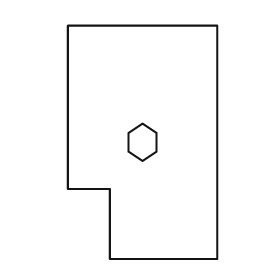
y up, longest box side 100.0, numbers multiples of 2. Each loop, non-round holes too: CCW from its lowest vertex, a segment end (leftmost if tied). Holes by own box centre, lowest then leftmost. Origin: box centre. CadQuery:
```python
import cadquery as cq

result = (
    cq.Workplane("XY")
    .moveTo(-14.0, -50.0)
    .lineTo(32.0, -50.0)
    .lineTo(32.0, 50.0)
    .lineTo(-32.0, 50.0)
    .lineTo(-32.0, -20.0)
    .lineTo(-14.0, -20.0)
    .close()
    .moveTo(0.0, -8.0)
    .lineTo(6.0, -4.0)
    .lineTo(6.0, 4.0)
    .lineTo(0.0, 8.0)
    .lineTo(-6.0, 4.0)
    .lineTo(-6.0, -4.0)
    .close()
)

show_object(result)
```